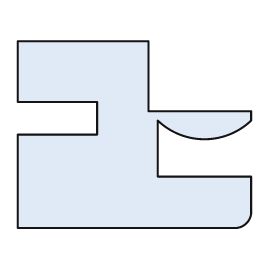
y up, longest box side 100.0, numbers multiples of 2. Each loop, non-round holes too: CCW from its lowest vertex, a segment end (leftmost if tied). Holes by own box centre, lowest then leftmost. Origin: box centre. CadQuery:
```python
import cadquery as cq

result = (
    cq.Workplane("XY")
    .moveTo(-50.0, -40.0)
    .lineTo(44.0, -40.0)
    .threePointArc((48.0, -38.0), (50.0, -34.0))
    .lineTo(50.0, -18.0)
    .lineTo(10.0, -18.0)
    .lineTo(10.0, 6.0)
    .threePointArc((30.0, -2.0), (50.0, 6.0))
    .lineTo(50.0, 10.0)
    .lineTo(6.0, 10.0)
    .lineTo(6.0, 40.0)
    .lineTo(-50.0, 40.0)
    .lineTo(-50.0, 14.0)
    .lineTo(-16.0, 14.0)
    .lineTo(-16.0, 0.0)
    .lineTo(-50.0, 0.0)
    .close()
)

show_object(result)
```